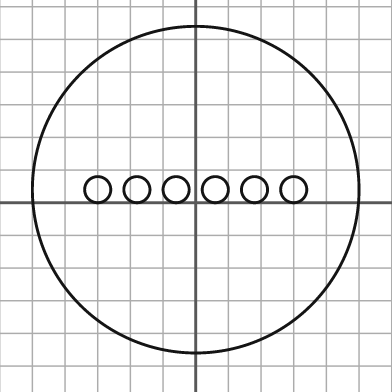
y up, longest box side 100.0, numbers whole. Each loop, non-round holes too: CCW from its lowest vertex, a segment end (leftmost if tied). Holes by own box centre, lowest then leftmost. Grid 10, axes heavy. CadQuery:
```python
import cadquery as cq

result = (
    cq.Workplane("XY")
    .moveTo(0.0, 4.0)
    .circle(50.0)
    .moveTo(-30.0, 4.0)
    .circle(4.0)
    .moveTo(-18.0, 4.0)
    .circle(4.0)
    .moveTo(-6.0, 4.0)
    .circle(4.0)
    .moveTo(6.0, 4.0)
    .circle(4.0)
    .moveTo(18.0, 4.0)
    .circle(4.0)
    .moveTo(30.0, 4.0)
    .circle(4.0)
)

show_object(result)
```